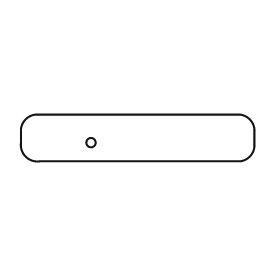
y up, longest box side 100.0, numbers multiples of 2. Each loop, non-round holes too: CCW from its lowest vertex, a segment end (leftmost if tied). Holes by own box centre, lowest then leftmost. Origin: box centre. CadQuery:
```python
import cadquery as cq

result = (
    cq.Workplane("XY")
    .moveTo(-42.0, -10.0)
    .lineTo(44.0, -10.0)
    .threePointArc((48.0, -8.0), (50.0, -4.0))
    .lineTo(50.0, 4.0)
    .threePointArc((48.0, 8.0), (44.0, 10.0))
    .lineTo(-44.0, 10.0)
    .threePointArc((-48.0, 8.0), (-50.0, 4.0))
    .lineTo(-50.0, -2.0)
    .threePointArc((-48.0, -8.0), (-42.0, -10.0))
    .close()
    .moveTo(-20.0, -2.0)
    .circle(2.0)
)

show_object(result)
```